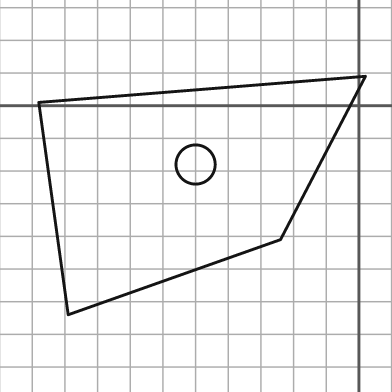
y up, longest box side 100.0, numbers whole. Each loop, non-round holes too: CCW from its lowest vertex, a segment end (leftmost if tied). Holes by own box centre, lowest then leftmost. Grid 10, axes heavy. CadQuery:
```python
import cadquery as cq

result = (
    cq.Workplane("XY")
    .moveTo(-89.0, -64.0)
    .lineTo(-24.0, -41.0)
    .lineTo(2.0, 9.0)
    .lineTo(-98.0, 1.0)
    .close()
    .moveTo(-50.0, -18.0)
    .circle(6.0)
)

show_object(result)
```